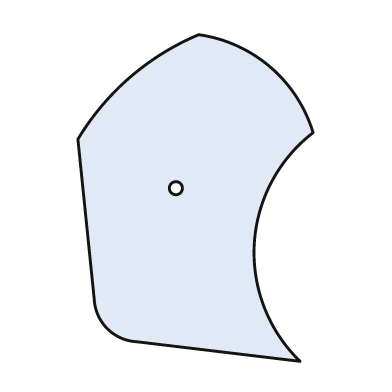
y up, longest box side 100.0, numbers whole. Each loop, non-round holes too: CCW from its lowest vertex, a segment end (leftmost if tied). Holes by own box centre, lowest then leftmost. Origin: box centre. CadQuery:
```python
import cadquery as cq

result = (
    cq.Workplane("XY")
    .moveTo(32.0, -50.0)
    .threePointArc((18.0, -14.0), (36.0, 20.0))
    .threePointArc((23.0, 40.0), (1.0, 50.0))
    .threePointArc((-20.0, 37.0), (-36.0, 18.0))
    .lineTo(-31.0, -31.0)
    .threePointArc((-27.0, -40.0), (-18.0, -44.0))
    .close()
    .moveTo(-6.0, 3.0)
    .circle(2.0)
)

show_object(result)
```